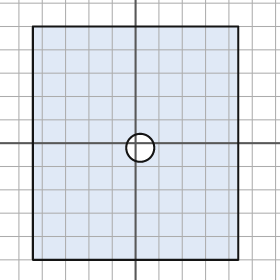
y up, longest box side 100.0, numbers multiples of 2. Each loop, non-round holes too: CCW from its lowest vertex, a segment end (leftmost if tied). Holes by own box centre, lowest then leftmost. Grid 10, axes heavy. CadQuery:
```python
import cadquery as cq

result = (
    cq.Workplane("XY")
    .moveTo(-44.0, -50.0)
    .lineTo(44.0, -50.0)
    .lineTo(44.0, 50.0)
    .lineTo(-44.0, 50.0)
    .close()
    .moveTo(2.0, -2.0)
    .circle(6.0)
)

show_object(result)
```